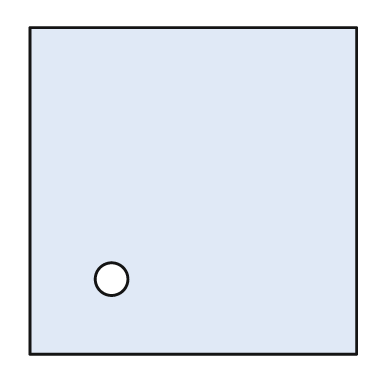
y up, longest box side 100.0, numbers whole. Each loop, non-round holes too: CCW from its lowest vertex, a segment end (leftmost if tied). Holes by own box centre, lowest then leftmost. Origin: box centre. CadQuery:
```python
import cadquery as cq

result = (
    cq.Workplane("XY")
    .moveTo(-50.0, -50.0)
    .lineTo(50.0, -50.0)
    .lineTo(50.0, 50.0)
    .lineTo(-50.0, 50.0)
    .close()
    .moveTo(-25.0, -27.0)
    .circle(5.0)
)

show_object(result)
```